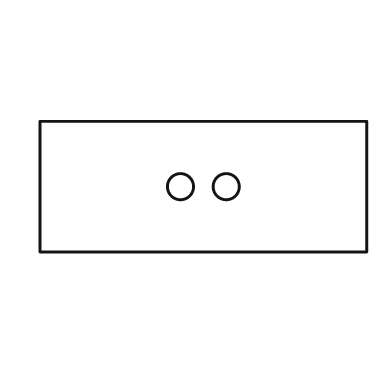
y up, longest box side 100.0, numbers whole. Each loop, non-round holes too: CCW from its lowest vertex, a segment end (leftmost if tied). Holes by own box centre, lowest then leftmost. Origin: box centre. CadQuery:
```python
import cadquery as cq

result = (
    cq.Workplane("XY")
    .moveTo(-50.0, -20.0)
    .lineTo(50.0, -20.0)
    .lineTo(50.0, 20.0)
    .lineTo(-50.0, 20.0)
    .close()
    .moveTo(-7.0, 0.0)
    .circle(4.0)
    .moveTo(7.0, 0.0)
    .circle(4.0)
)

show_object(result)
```